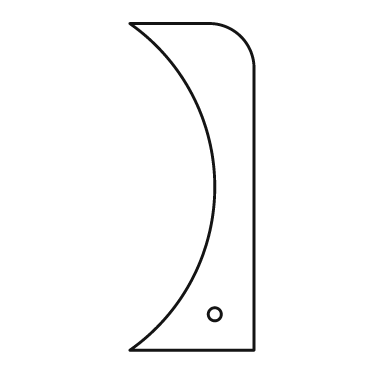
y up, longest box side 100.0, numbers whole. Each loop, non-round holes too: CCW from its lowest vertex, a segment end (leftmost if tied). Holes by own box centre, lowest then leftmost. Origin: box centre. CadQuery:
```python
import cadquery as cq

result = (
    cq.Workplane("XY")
    .moveTo(-19.0, -50.0)
    .lineTo(19.0, -50.0)
    .lineTo(19.0, 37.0)
    .threePointArc((15.0, 46.0), (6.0, 50.0))
    .lineTo(-19.0, 50.0)
    .threePointArc((7.0, 0.0), (-19.0, -50.0))
    .close()
    .moveTo(7.0, -39.0)
    .circle(2.0)
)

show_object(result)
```